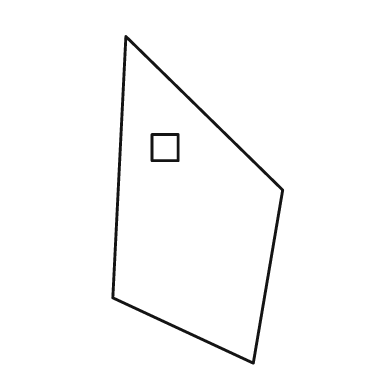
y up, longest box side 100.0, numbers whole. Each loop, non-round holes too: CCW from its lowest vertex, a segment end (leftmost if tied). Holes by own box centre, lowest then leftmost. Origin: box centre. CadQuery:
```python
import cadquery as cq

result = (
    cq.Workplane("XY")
    .moveTo(17.0, -50.0)
    .lineTo(26.0, 3.0)
    .lineTo(-22.0, 50.0)
    .lineTo(-26.0, -30.0)
    .close()
    .moveTo(-14.0, 12.0)
    .lineTo(-6.0, 12.0)
    .lineTo(-6.0, 20.0)
    .lineTo(-14.0, 20.0)
    .close()
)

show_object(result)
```